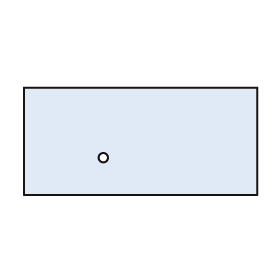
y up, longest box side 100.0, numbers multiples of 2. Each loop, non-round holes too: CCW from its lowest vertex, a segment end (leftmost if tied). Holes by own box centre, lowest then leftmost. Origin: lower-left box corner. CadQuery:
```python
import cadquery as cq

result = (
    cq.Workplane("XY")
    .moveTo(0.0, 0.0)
    .lineTo(100.0, 0.0)
    .lineTo(100.0, 46.0)
    .lineTo(0.0, 46.0)
    .close()
    .moveTo(34.0, 16.0)
    .circle(2.0)
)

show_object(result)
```